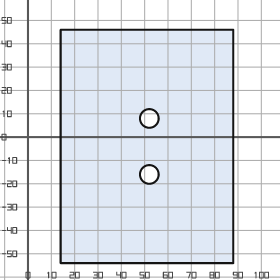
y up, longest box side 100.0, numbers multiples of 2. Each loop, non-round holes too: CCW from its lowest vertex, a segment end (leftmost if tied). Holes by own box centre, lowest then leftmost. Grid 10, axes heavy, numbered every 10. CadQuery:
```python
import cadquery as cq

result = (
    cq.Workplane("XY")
    .moveTo(14.0, -54.0)
    .lineTo(88.0, -54.0)
    .lineTo(88.0, 46.0)
    .lineTo(14.0, 46.0)
    .close()
    .moveTo(52.0, -16.0)
    .circle(4.0)
    .moveTo(52.0, 8.0)
    .circle(4.0)
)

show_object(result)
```